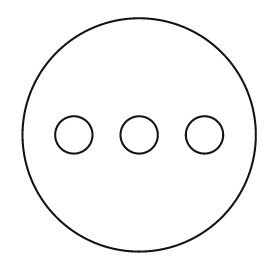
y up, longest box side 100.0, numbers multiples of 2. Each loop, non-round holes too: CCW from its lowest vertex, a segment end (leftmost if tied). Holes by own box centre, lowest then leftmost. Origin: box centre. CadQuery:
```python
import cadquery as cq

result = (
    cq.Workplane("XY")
    .moveTo(0.0, 0.0)
    .circle(50.0)
    .moveTo(-28.0, 0.0)
    .circle(8.0)
    .moveTo(0.0, 0.0)
    .circle(8.0)
    .moveTo(28.0, 0.0)
    .circle(8.0)
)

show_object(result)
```